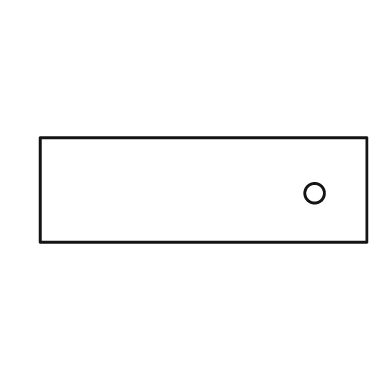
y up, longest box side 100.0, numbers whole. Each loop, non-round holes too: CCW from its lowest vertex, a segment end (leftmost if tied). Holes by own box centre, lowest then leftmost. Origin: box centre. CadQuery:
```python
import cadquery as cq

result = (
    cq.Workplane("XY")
    .moveTo(-50.0, -16.0)
    .lineTo(50.0, -16.0)
    .lineTo(50.0, 16.0)
    .lineTo(-50.0, 16.0)
    .close()
    .moveTo(34.0, -1.0)
    .circle(3.0)
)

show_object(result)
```